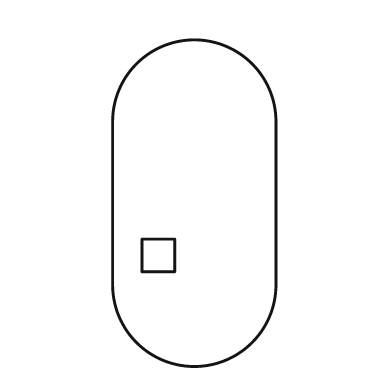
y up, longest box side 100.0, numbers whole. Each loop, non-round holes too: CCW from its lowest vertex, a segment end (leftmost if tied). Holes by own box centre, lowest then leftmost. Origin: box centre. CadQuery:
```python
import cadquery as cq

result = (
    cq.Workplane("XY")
    .moveTo(-25.0, -25.0)
    .threePointArc((0.0, -50.0), (25.0, -25.0))
    .lineTo(25.0, 25.0)
    .threePointArc((0.0, 50.0), (-25.0, 25.0))
    .close()
    .moveTo(-16.0, -21.0)
    .lineTo(-6.0, -21.0)
    .lineTo(-6.0, -11.0)
    .lineTo(-16.0, -11.0)
    .close()
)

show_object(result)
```